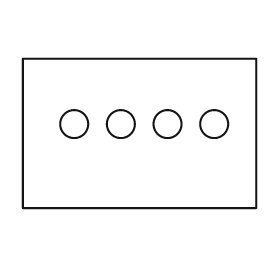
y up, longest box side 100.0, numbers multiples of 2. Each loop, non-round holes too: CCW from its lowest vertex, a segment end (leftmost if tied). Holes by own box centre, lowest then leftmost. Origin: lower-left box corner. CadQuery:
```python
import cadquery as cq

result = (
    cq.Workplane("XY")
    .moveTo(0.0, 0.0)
    .lineTo(100.0, 0.0)
    .lineTo(100.0, 64.0)
    .lineTo(0.0, 64.0)
    .close()
    .moveTo(22.0, 36.0)
    .circle(6.0)
    .moveTo(42.0, 36.0)
    .circle(6.0)
    .moveTo(62.0, 36.0)
    .circle(6.0)
    .moveTo(82.0, 36.0)
    .circle(6.0)
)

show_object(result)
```